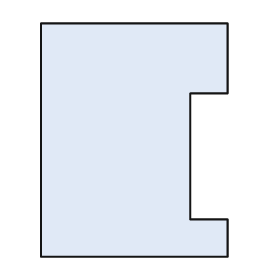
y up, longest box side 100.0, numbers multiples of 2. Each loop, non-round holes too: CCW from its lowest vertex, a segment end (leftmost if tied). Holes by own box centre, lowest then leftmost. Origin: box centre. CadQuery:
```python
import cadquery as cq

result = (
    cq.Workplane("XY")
    .moveTo(-40.0, -50.0)
    .lineTo(40.0, -50.0)
    .lineTo(40.0, -34.0)
    .lineTo(24.0, -34.0)
    .lineTo(24.0, 20.0)
    .lineTo(40.0, 20.0)
    .lineTo(40.0, 50.0)
    .lineTo(-40.0, 50.0)
    .close()
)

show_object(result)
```